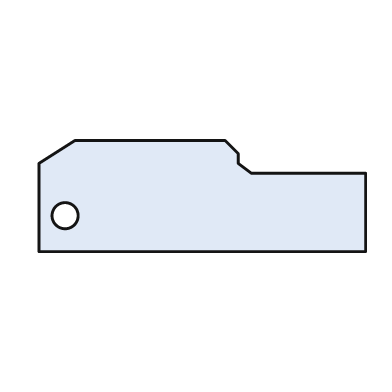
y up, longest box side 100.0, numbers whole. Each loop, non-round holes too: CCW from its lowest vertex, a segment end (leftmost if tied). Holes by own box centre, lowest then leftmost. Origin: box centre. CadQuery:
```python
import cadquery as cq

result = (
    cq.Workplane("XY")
    .moveTo(-50.0, -17.0)
    .lineTo(50.0, -17.0)
    .lineTo(50.0, 7.0)
    .lineTo(15.0, 7.0)
    .lineTo(11.0, 10.0)
    .lineTo(11.0, 13.0)
    .lineTo(7.0, 17.0)
    .lineTo(-39.0, 17.0)
    .lineTo(-50.0, 10.0)
    .close()
    .moveTo(-42.0, -6.0)
    .circle(4.0)
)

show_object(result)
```